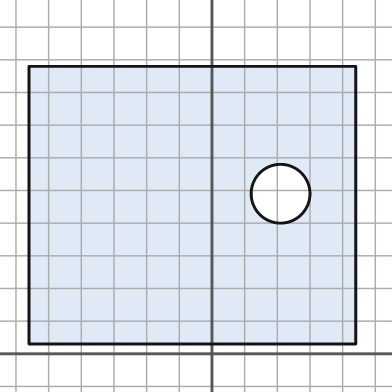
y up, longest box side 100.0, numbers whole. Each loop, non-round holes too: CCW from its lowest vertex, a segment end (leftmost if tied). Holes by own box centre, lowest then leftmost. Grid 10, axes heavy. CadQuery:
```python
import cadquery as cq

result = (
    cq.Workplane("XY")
    .moveTo(-56.0, 3.0)
    .lineTo(44.0, 3.0)
    .lineTo(44.0, 88.0)
    .lineTo(-56.0, 88.0)
    .close()
    .moveTo(21.0, 49.0)
    .circle(9.0)
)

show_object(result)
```